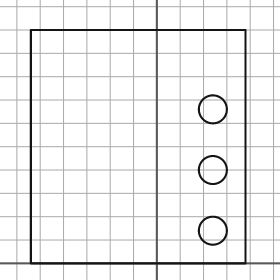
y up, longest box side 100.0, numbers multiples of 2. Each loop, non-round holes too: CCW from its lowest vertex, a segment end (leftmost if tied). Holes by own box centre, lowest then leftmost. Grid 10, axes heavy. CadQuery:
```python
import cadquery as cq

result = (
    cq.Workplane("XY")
    .moveTo(-54.0, 0.0)
    .lineTo(38.0, 0.0)
    .lineTo(38.0, 100.0)
    .lineTo(-54.0, 100.0)
    .close()
    .moveTo(24.0, 14.0)
    .circle(6.0)
    .moveTo(24.0, 40.0)
    .circle(6.0)
    .moveTo(24.0, 66.0)
    .circle(6.0)
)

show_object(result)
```